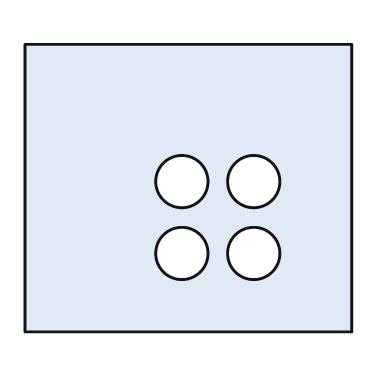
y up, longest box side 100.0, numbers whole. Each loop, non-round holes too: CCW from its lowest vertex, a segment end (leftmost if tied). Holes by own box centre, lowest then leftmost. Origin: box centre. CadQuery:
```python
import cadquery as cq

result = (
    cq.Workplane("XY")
    .moveTo(-50.0, -44.0)
    .lineTo(50.0, -44.0)
    .lineTo(50.0, 44.0)
    .lineTo(-50.0, 44.0)
    .close()
    .moveTo(-2.0, -20.0)
    .circle(8.0)
    .moveTo(20.0, -20.0)
    .circle(8.0)
    .moveTo(-2.0, 2.0)
    .circle(8.0)
    .moveTo(20.0, 2.0)
    .circle(8.0)
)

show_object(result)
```